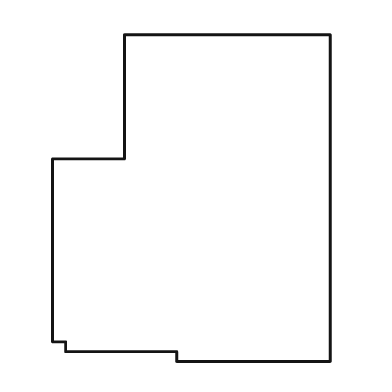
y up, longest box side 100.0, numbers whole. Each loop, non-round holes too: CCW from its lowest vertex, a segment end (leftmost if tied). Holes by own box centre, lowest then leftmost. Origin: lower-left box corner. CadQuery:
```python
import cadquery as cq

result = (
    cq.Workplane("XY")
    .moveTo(38.0, 0.0)
    .lineTo(85.0, 0.0)
    .lineTo(85.0, 100.0)
    .lineTo(22.0, 100.0)
    .lineTo(22.0, 62.0)
    .lineTo(0.0, 62.0)
    .lineTo(0.0, 6.0)
    .lineTo(4.0, 6.0)
    .lineTo(4.0, 3.0)
    .lineTo(38.0, 3.0)
    .close()
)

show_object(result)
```